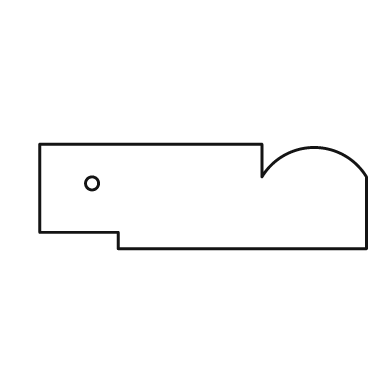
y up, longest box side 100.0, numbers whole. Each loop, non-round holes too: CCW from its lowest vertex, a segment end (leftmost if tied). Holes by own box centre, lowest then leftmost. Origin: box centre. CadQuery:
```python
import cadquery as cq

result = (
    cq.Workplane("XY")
    .moveTo(-26.0, -16.0)
    .lineTo(50.0, -16.0)
    .lineTo(50.0, 6.0)
    .threePointArc((34.0, 15.0), (18.0, 6.0))
    .lineTo(18.0, 16.0)
    .lineTo(-50.0, 16.0)
    .lineTo(-50.0, -11.0)
    .lineTo(-26.0, -11.0)
    .close()
    .moveTo(-34.0, 4.0)
    .circle(2.0)
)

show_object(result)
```